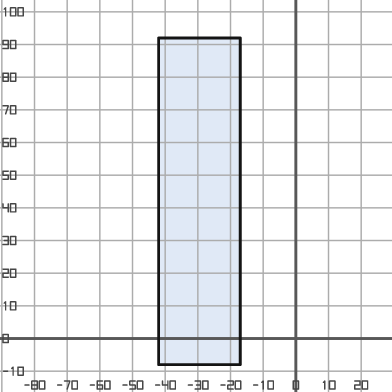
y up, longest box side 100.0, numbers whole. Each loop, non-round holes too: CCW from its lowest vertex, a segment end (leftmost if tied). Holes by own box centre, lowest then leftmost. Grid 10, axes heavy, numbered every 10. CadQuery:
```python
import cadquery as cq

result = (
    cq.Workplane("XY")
    .moveTo(-42.0, -8.0)
    .lineTo(-17.0, -8.0)
    .lineTo(-17.0, 92.0)
    .lineTo(-42.0, 92.0)
    .close()
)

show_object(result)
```